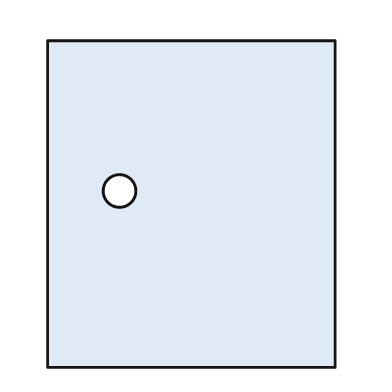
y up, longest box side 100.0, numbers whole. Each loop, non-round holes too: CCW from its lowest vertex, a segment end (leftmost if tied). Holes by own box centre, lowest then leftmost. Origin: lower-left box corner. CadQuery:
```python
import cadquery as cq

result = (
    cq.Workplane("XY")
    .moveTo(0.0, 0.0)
    .lineTo(88.0, 0.0)
    .lineTo(88.0, 100.0)
    .lineTo(0.0, 100.0)
    .close()
    .moveTo(22.0, 54.0)
    .circle(5.0)
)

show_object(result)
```